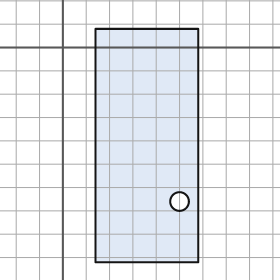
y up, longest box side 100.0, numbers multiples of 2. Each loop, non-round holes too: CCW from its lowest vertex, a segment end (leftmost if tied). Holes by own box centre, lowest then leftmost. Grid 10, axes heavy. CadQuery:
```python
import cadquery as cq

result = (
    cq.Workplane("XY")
    .moveTo(14.0, -92.0)
    .lineTo(58.0, -92.0)
    .lineTo(58.0, 8.0)
    .lineTo(14.0, 8.0)
    .close()
    .moveTo(50.0, -66.0)
    .circle(4.0)
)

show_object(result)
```